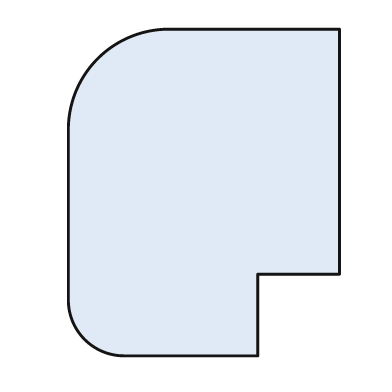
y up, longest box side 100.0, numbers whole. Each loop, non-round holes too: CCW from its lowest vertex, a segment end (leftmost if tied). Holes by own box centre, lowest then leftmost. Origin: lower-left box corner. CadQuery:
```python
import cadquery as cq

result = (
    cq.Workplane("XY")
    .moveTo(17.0, 0.0)
    .lineTo(58.0, 0.0)
    .lineTo(58.0, 25.0)
    .lineTo(83.0, 25.0)
    .lineTo(83.0, 100.0)
    .lineTo(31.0, 100.0)
    .threePointArc((9.0, 91.0), (0.0, 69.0))
    .lineTo(0.0, 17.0)
    .threePointArc((5.0, 5.0), (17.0, 0.0))
    .close()
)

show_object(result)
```